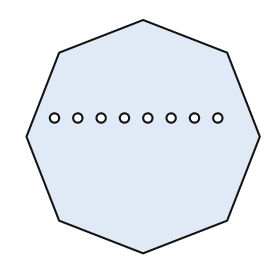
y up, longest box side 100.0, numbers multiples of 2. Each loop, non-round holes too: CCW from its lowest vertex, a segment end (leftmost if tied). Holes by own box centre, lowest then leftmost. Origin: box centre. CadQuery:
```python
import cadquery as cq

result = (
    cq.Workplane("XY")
    .moveTo(0.0, -50.0)
    .lineTo(36.0, -36.0)
    .lineTo(50.0, 0.0)
    .lineTo(36.0, 36.0)
    .lineTo(0.0, 50.0)
    .lineTo(-36.0, 36.0)
    .lineTo(-50.0, 0.0)
    .lineTo(-36.0, -36.0)
    .close()
    .moveTo(-38.0, 8.0)
    .circle(2.0)
    .moveTo(-28.0, 8.0)
    .circle(2.0)
    .moveTo(-18.0, 8.0)
    .circle(2.0)
    .moveTo(-8.0, 8.0)
    .circle(2.0)
    .moveTo(2.0, 8.0)
    .circle(2.0)
    .moveTo(12.0, 8.0)
    .circle(2.0)
    .moveTo(22.0, 8.0)
    .circle(2.0)
    .moveTo(32.0, 8.0)
    .circle(2.0)
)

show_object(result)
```